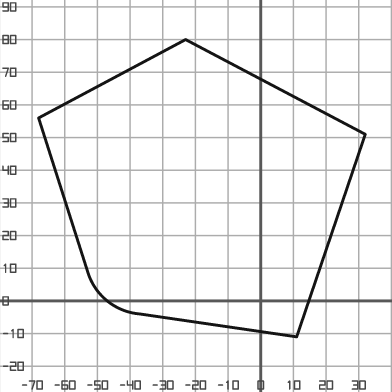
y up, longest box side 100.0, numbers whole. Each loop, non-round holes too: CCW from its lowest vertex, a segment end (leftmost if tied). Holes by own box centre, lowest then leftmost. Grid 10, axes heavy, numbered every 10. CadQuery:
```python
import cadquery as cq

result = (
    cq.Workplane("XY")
    .moveTo(11.0, -11.0)
    .lineTo(32.0, 51.0)
    .lineTo(-23.0, 80.0)
    .lineTo(-68.0, 56.0)
    .lineTo(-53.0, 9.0)
    .threePointArc((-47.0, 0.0), (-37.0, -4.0))
    .close()
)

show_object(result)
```